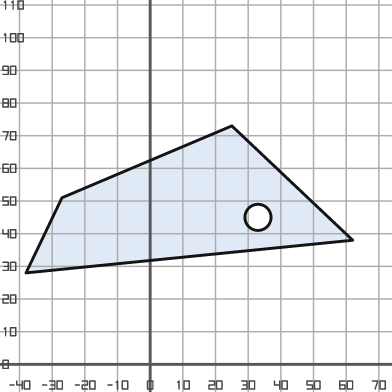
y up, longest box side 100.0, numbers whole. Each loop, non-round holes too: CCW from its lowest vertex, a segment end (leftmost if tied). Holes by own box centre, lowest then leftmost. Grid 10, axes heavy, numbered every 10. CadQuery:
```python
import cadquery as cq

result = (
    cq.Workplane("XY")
    .moveTo(-38.0, 28.0)
    .lineTo(62.0, 38.0)
    .lineTo(25.0, 73.0)
    .lineTo(-27.0, 51.0)
    .close()
    .moveTo(33.0, 45.0)
    .circle(4.0)
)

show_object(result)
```